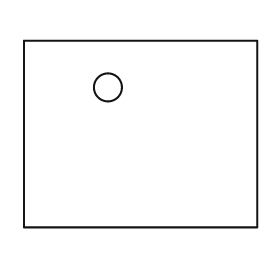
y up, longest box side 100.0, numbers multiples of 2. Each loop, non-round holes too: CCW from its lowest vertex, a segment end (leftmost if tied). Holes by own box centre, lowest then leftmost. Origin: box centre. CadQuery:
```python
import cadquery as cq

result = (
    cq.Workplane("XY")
    .moveTo(-50.0, -40.0)
    .lineTo(50.0, -40.0)
    .lineTo(50.0, 40.0)
    .lineTo(-50.0, 40.0)
    .close()
    .moveTo(-14.0, 20.0)
    .circle(6.0)
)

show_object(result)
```